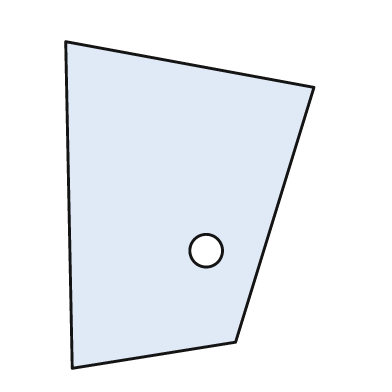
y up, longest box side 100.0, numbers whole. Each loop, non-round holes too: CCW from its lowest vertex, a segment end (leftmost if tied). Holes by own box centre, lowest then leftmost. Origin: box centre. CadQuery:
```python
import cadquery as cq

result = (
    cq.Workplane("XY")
    .moveTo(-36.0, -50.0)
    .lineTo(14.0, -42.0)
    .lineTo(38.0, 36.0)
    .lineTo(-38.0, 50.0)
    .close()
    .moveTo(5.0, -14.0)
    .circle(5.0)
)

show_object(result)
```